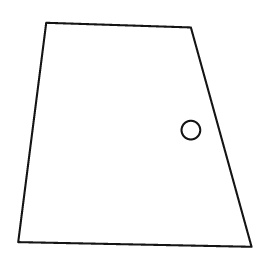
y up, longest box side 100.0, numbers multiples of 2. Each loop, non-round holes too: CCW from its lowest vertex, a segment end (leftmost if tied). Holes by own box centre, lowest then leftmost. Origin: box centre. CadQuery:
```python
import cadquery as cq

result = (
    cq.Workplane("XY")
    .moveTo(50.0, -48.0)
    .lineTo(24.0, 46.0)
    .lineTo(-38.0, 48.0)
    .lineTo(-50.0, -46.0)
    .close()
    .moveTo(24.0, 2.0)
    .circle(4.0)
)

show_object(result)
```